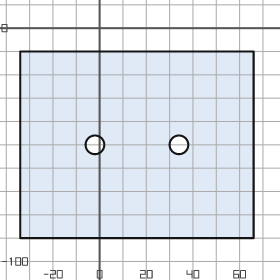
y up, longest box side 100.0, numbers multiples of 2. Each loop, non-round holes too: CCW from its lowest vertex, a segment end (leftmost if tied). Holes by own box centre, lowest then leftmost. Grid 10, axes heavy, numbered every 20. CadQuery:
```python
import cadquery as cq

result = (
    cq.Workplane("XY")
    .moveTo(-34.0, -90.0)
    .lineTo(66.0, -90.0)
    .lineTo(66.0, -10.0)
    .lineTo(-34.0, -10.0)
    .close()
    .moveTo(-2.0, -50.0)
    .circle(4.0)
    .moveTo(34.0, -50.0)
    .circle(4.0)
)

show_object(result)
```